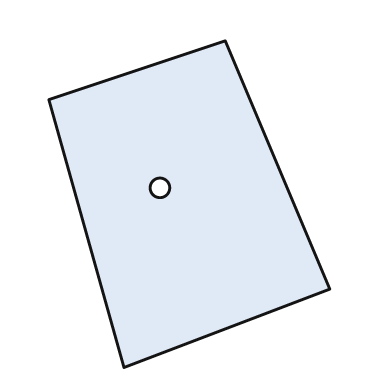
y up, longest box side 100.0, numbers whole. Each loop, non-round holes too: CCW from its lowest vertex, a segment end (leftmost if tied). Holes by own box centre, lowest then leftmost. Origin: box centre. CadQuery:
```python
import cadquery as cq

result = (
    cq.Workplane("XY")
    .moveTo(-20.0, -50.0)
    .lineTo(43.0, -26.0)
    .lineTo(11.0, 50.0)
    .lineTo(-43.0, 32.0)
    .close()
    .moveTo(-9.0, 5.0)
    .circle(3.0)
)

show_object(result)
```